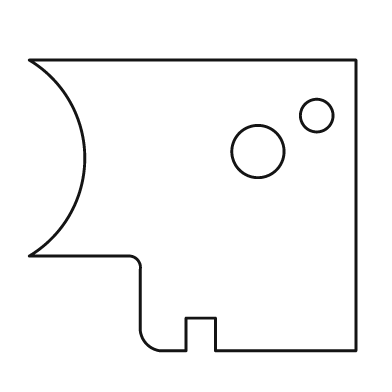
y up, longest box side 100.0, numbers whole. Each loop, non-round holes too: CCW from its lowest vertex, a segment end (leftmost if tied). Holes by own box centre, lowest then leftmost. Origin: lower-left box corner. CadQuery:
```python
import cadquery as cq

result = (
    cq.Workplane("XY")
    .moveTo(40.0, 0.0)
    .lineTo(48.0, 0.0)
    .lineTo(48.0, 10.0)
    .lineTo(57.0, 10.0)
    .lineTo(57.0, 0.0)
    .lineTo(100.0, 0.0)
    .lineTo(100.0, 89.0)
    .lineTo(0.0, 89.0)
    .threePointArc((17.0, 59.0), (0.0, 29.0))
    .lineTo(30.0, 29.0)
    .threePointArc((33.0, 28.0), (34.0, 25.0))
    .lineTo(34.0, 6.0)
    .threePointArc((36.0, 2.0), (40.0, 0.0))
    .close()
    .moveTo(70.0, 61.0)
    .circle(8.0)
    .moveTo(88.0, 72.0)
    .circle(5.0)
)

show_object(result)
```